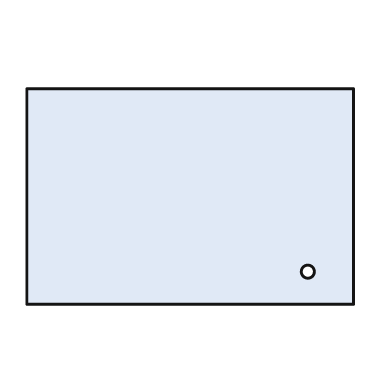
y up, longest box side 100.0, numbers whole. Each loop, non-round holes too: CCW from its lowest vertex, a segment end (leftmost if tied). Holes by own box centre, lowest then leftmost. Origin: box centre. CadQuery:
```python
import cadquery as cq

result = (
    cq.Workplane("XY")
    .moveTo(-50.0, -33.0)
    .lineTo(50.0, -33.0)
    .lineTo(50.0, 33.0)
    .lineTo(-50.0, 33.0)
    .close()
    .moveTo(36.0, -23.0)
    .circle(2.0)
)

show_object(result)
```